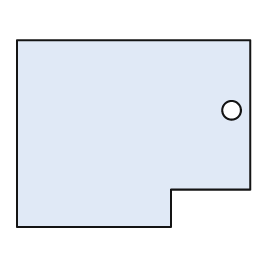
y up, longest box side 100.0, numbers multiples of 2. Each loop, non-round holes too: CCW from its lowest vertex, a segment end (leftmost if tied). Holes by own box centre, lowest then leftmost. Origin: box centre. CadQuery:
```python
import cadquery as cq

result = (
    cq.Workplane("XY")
    .moveTo(-50.0, -40.0)
    .lineTo(16.0, -40.0)
    .lineTo(16.0, -24.0)
    .lineTo(50.0, -24.0)
    .lineTo(50.0, 40.0)
    .lineTo(-50.0, 40.0)
    .close()
    .moveTo(42.0, 10.0)
    .circle(4.0)
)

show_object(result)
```